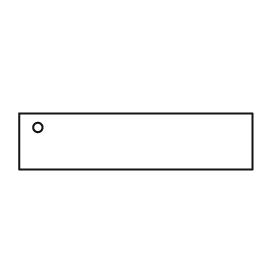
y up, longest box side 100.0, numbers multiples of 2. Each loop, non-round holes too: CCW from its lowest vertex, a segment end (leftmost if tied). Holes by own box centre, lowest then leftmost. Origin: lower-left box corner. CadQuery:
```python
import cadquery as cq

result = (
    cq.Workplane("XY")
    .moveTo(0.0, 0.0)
    .lineTo(100.0, 0.0)
    .lineTo(100.0, 24.0)
    .lineTo(0.0, 24.0)
    .close()
    .moveTo(8.0, 18.0)
    .circle(2.0)
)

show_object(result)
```